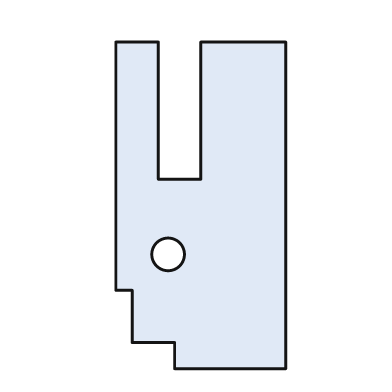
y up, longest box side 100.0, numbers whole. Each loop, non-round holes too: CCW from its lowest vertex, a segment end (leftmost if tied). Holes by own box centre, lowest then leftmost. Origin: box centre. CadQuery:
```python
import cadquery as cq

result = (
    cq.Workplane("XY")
    .moveTo(-8.0, -50.0)
    .lineTo(26.0, -50.0)
    .lineTo(26.0, 50.0)
    .lineTo(0.0, 50.0)
    .lineTo(0.0, 8.0)
    .lineTo(-13.0, 8.0)
    .lineTo(-13.0, 50.0)
    .lineTo(-26.0, 50.0)
    .lineTo(-26.0, -26.0)
    .lineTo(-21.0, -26.0)
    .lineTo(-21.0, -42.0)
    .lineTo(-8.0, -42.0)
    .close()
    .moveTo(-10.0, -15.0)
    .circle(5.0)
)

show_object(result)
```